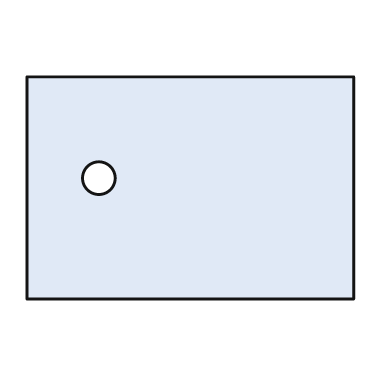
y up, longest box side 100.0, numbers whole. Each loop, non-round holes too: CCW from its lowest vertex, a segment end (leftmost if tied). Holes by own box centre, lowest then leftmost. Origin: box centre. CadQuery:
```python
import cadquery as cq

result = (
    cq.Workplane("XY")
    .moveTo(-50.0, -34.0)
    .lineTo(50.0, -34.0)
    .lineTo(50.0, 34.0)
    .lineTo(-50.0, 34.0)
    .close()
    .moveTo(-28.0, 3.0)
    .circle(5.0)
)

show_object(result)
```